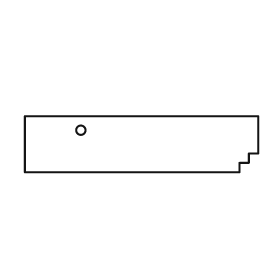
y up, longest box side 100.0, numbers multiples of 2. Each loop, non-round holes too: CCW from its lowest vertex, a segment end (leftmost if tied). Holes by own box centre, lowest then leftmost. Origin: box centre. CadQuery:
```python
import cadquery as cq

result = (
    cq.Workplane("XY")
    .moveTo(-50.0, -12.0)
    .lineTo(42.0, -12.0)
    .lineTo(42.0, -8.0)
    .lineTo(46.0, -8.0)
    .lineTo(46.0, -4.0)
    .lineTo(50.0, -4.0)
    .lineTo(50.0, 12.0)
    .lineTo(-50.0, 12.0)
    .close()
    .moveTo(-26.0, 6.0)
    .circle(2.0)
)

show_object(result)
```